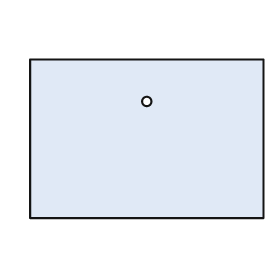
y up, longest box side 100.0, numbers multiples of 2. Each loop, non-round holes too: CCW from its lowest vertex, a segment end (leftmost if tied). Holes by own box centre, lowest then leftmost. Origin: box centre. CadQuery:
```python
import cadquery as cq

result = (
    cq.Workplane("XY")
    .moveTo(-50.0, -34.0)
    .lineTo(50.0, -34.0)
    .lineTo(50.0, 34.0)
    .lineTo(-50.0, 34.0)
    .close()
    .moveTo(0.0, 16.0)
    .circle(2.0)
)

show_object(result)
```